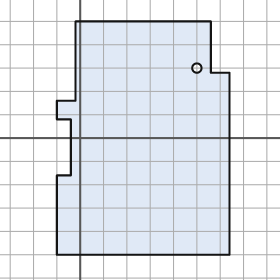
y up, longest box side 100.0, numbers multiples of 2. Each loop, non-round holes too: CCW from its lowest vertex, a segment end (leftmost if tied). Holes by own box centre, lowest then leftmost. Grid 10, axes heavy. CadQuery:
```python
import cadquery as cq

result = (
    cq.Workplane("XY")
    .moveTo(-10.0, -50.0)
    .lineTo(64.0, -50.0)
    .lineTo(64.0, 28.0)
    .lineTo(56.0, 28.0)
    .lineTo(56.0, 50.0)
    .lineTo(-2.0, 50.0)
    .lineTo(-2.0, 16.0)
    .lineTo(-10.0, 16.0)
    .lineTo(-10.0, 8.0)
    .lineTo(-4.0, 8.0)
    .lineTo(-4.0, -16.0)
    .lineTo(-10.0, -16.0)
    .close()
    .moveTo(50.0, 30.0)
    .circle(2.0)
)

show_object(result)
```